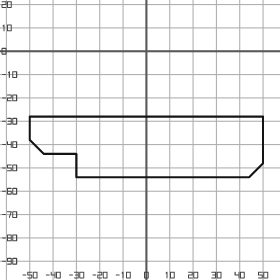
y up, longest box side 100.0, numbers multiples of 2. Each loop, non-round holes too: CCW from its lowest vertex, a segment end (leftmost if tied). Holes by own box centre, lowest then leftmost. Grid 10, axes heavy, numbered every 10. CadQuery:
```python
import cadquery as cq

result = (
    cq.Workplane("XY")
    .moveTo(-30.0, -54.0)
    .lineTo(44.0, -54.0)
    .lineTo(50.0, -48.0)
    .lineTo(50.0, -28.0)
    .lineTo(-50.0, -28.0)
    .lineTo(-50.0, -38.0)
    .lineTo(-44.0, -44.0)
    .lineTo(-30.0, -44.0)
    .close()
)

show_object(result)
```